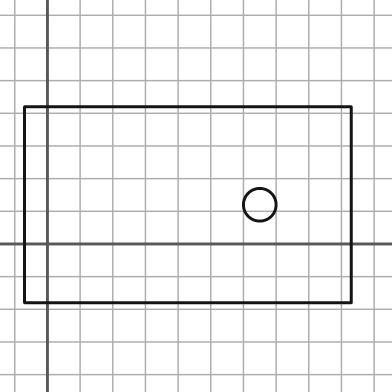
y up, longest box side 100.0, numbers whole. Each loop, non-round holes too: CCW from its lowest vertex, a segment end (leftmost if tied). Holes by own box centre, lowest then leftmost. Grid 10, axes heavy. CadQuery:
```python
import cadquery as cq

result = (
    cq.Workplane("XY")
    .moveTo(-7.0, -18.0)
    .lineTo(93.0, -18.0)
    .lineTo(93.0, 42.0)
    .lineTo(-7.0, 42.0)
    .close()
    .moveTo(65.0, 12.0)
    .circle(5.0)
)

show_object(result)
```